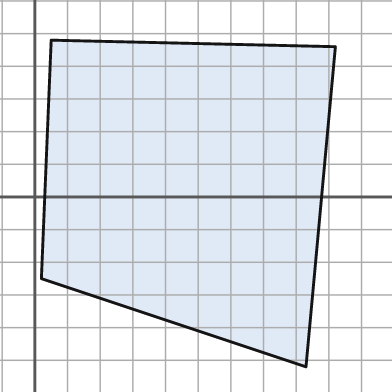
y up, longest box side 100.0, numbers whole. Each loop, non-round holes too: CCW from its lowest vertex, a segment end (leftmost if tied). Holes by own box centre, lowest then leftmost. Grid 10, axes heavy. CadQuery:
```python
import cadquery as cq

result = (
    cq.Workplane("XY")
    .moveTo(83.0, -52.0)
    .lineTo(92.0, 46.0)
    .lineTo(5.0, 48.0)
    .lineTo(2.0, -25.0)
    .close()
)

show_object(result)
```